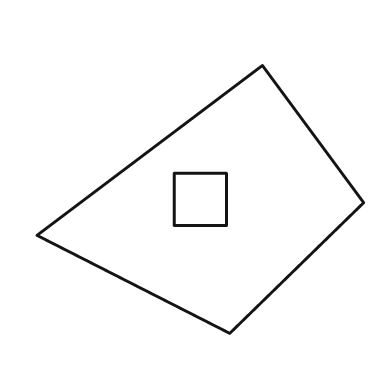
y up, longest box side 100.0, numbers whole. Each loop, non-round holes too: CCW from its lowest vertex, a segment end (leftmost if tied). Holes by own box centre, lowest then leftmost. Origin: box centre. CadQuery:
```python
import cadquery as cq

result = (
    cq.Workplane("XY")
    .moveTo(9.0, -41.0)
    .lineTo(50.0, -1.0)
    .lineTo(19.0, 41.0)
    .lineTo(-50.0, -11.0)
    .close()
    .moveTo(-8.0, -8.0)
    .lineTo(8.0, -8.0)
    .lineTo(8.0, 8.0)
    .lineTo(-8.0, 8.0)
    .close()
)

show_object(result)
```